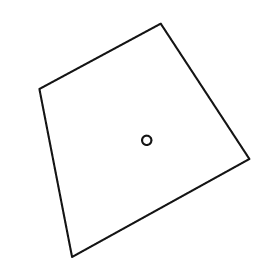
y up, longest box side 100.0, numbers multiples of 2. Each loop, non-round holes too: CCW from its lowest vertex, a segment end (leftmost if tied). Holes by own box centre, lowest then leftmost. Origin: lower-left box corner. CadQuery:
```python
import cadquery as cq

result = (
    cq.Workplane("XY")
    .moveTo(14.0, 0.0)
    .lineTo(90.0, 42.0)
    .lineTo(52.0, 100.0)
    .lineTo(0.0, 72.0)
    .close()
    .moveTo(46.0, 50.0)
    .circle(2.0)
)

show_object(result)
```